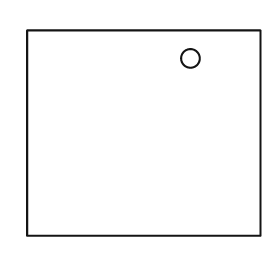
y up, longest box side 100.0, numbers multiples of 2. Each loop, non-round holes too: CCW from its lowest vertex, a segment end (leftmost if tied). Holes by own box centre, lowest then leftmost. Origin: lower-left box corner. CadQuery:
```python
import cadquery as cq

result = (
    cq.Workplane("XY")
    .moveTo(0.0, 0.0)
    .lineTo(100.0, 0.0)
    .lineTo(100.0, 88.0)
    .lineTo(0.0, 88.0)
    .close()
    .moveTo(70.0, 76.0)
    .circle(4.0)
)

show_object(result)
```